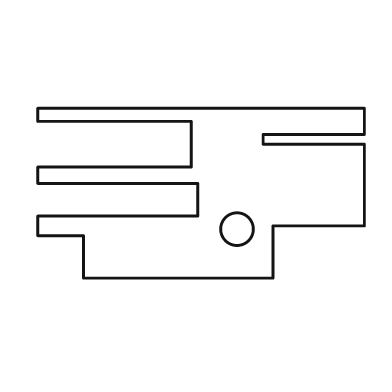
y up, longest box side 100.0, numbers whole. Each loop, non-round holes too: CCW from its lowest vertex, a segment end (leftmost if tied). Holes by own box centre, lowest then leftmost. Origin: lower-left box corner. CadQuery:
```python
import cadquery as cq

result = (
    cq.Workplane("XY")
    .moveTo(14.0, 0.0)
    .lineTo(72.0, 0.0)
    .lineTo(72.0, 16.0)
    .lineTo(100.0, 16.0)
    .lineTo(100.0, 41.0)
    .lineTo(69.0, 41.0)
    .lineTo(69.0, 44.0)
    .lineTo(100.0, 44.0)
    .lineTo(100.0, 52.0)
    .lineTo(0.0, 52.0)
    .lineTo(0.0, 48.0)
    .lineTo(47.0, 48.0)
    .lineTo(47.0, 34.0)
    .lineTo(0.0, 34.0)
    .lineTo(0.0, 29.0)
    .lineTo(49.0, 29.0)
    .lineTo(49.0, 19.0)
    .lineTo(0.0, 19.0)
    .lineTo(0.0, 13.0)
    .lineTo(14.0, 13.0)
    .close()
    .moveTo(61.0, 15.0)
    .circle(5.0)
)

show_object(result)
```